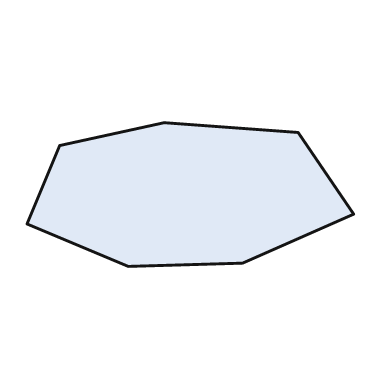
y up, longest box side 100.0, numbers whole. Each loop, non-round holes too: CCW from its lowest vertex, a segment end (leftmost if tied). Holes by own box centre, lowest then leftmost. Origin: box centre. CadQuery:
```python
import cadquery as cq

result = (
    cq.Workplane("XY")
    .moveTo(-19.0, -22.0)
    .lineTo(16.0, -21.0)
    .lineTo(50.0, -6.0)
    .lineTo(33.0, 19.0)
    .lineTo(-8.0, 22.0)
    .lineTo(-40.0, 15.0)
    .lineTo(-50.0, -9.0)
    .close()
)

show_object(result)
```